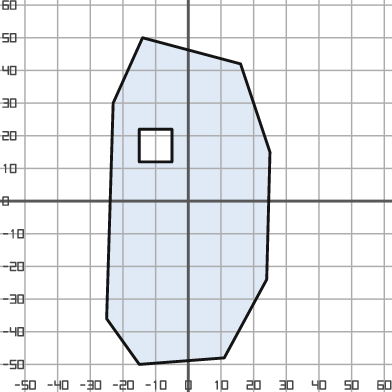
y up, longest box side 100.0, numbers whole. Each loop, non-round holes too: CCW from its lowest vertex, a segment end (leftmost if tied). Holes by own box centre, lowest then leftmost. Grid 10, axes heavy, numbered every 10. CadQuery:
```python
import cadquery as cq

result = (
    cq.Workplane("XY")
    .moveTo(-15.0, -50.0)
    .lineTo(11.0, -48.0)
    .lineTo(24.0, -24.0)
    .lineTo(25.0, 15.0)
    .lineTo(16.0, 42.0)
    .lineTo(-14.0, 50.0)
    .lineTo(-23.0, 30.0)
    .lineTo(-25.0, -36.0)
    .close()
    .moveTo(-15.0, 12.0)
    .lineTo(-5.0, 12.0)
    .lineTo(-5.0, 22.0)
    .lineTo(-15.0, 22.0)
    .close()
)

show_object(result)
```